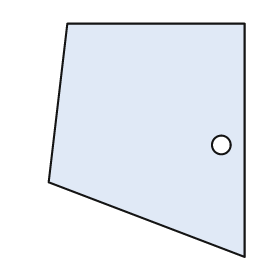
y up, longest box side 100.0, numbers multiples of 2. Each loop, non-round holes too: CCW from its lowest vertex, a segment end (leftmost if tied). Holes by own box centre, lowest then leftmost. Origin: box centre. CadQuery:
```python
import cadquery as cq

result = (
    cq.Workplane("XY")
    .moveTo(42.0, -50.0)
    .lineTo(42.0, 50.0)
    .lineTo(-34.0, 50.0)
    .lineTo(-42.0, -18.0)
    .close()
    .moveTo(32.0, -2.0)
    .circle(4.0)
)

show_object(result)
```